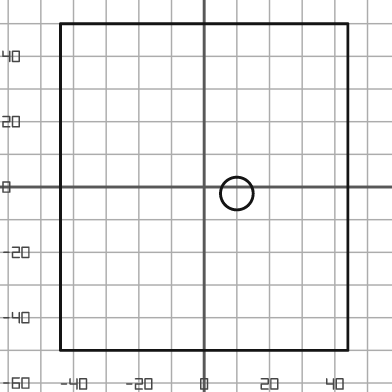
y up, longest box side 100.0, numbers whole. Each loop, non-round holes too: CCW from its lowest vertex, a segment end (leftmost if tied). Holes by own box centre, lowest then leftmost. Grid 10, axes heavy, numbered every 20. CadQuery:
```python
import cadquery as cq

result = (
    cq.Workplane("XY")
    .moveTo(-44.0, -50.0)
    .lineTo(44.0, -50.0)
    .lineTo(44.0, 50.0)
    .lineTo(-44.0, 50.0)
    .close()
    .moveTo(10.0, -2.0)
    .circle(5.0)
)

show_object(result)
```